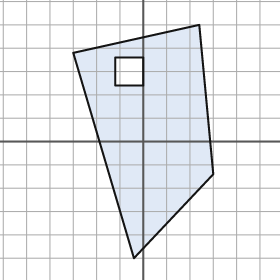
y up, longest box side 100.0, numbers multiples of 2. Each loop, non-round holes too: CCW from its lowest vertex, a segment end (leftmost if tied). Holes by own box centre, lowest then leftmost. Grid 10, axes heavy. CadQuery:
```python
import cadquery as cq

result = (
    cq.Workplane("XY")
    .moveTo(-4.0, -50.0)
    .lineTo(30.0, -14.0)
    .lineTo(24.0, 50.0)
    .lineTo(-30.0, 38.0)
    .close()
    .moveTo(-12.0, 24.0)
    .lineTo(0.0, 24.0)
    .lineTo(0.0, 36.0)
    .lineTo(-12.0, 36.0)
    .close()
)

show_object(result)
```